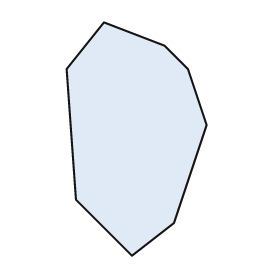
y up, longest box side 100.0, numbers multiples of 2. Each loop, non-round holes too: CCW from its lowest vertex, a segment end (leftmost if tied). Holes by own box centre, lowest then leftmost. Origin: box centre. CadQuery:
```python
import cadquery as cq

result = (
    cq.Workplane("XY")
    .moveTo(-2.0, -50.0)
    .lineTo(16.0, -36.0)
    .lineTo(30.0, 6.0)
    .lineTo(22.0, 30.0)
    .lineTo(12.0, 40.0)
    .lineTo(-14.0, 50.0)
    .lineTo(-30.0, 30.0)
    .lineTo(-26.0, -26.0)
    .close()
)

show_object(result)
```